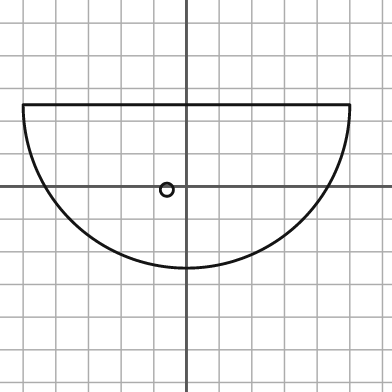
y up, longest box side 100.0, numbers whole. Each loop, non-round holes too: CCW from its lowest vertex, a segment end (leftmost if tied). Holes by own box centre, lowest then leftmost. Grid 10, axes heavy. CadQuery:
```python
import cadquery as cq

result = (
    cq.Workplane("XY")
    .moveTo(-50.0, 25.0)
    .threePointArc((0.0, -25.0), (50.0, 25.0))
    .close()
    .moveTo(-6.0, -1.0)
    .circle(2.0)
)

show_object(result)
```